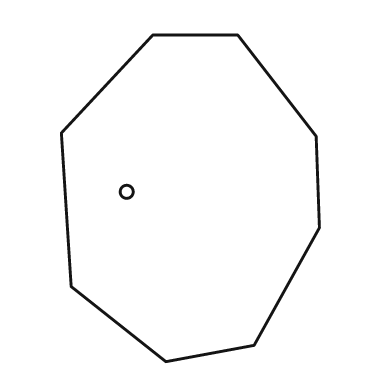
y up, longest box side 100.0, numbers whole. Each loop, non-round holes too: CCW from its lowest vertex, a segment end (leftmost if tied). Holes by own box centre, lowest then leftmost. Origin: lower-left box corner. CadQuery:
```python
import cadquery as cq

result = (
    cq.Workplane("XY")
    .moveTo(32.0, 0.0)
    .lineTo(59.0, 5.0)
    .lineTo(79.0, 41.0)
    .lineTo(78.0, 69.0)
    .lineTo(54.0, 100.0)
    .lineTo(28.0, 100.0)
    .lineTo(0.0, 70.0)
    .lineTo(3.0, 23.0)
    .close()
    .moveTo(20.0, 52.0)
    .circle(2.0)
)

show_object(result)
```